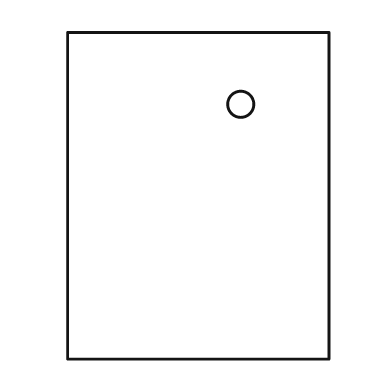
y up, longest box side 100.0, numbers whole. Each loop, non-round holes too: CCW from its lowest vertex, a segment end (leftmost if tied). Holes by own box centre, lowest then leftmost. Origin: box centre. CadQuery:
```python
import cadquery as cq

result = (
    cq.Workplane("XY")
    .moveTo(-40.0, -50.0)
    .lineTo(40.0, -50.0)
    .lineTo(40.0, 50.0)
    .lineTo(-40.0, 50.0)
    .close()
    .moveTo(13.0, 28.0)
    .circle(4.0)
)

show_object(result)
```